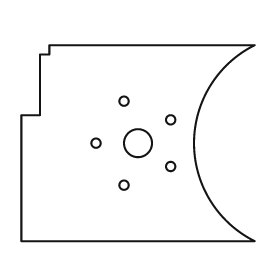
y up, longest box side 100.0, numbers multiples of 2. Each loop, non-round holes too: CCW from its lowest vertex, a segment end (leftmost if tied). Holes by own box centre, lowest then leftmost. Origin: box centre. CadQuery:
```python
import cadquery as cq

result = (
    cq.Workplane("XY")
    .moveTo(-50.0, -42.0)
    .lineTo(50.0, -42.0)
    .threePointArc((24.0, 0.0), (50.0, 42.0))
    .lineTo(-38.0, 42.0)
    .lineTo(-38.0, 38.0)
    .lineTo(-42.0, 38.0)
    .lineTo(-42.0, 12.0)
    .lineTo(-50.0, 12.0)
    .close()
    .moveTo(-6.0, -18.0)
    .circle(2.0)
    .moveTo(14.0, -10.0)
    .circle(2.0)
    .moveTo(-18.0, 0.0)
    .circle(2.0)
    .moveTo(0.0, 0.0)
    .circle(6.0)
    .moveTo(14.0, 10.0)
    .circle(2.0)
    .moveTo(-6.0, 18.0)
    .circle(2.0)
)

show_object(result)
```